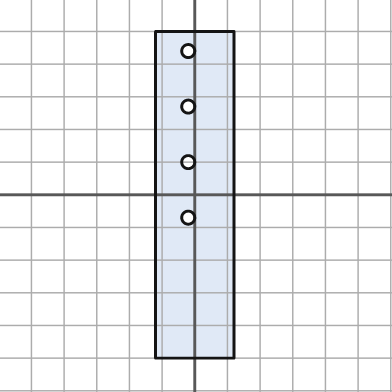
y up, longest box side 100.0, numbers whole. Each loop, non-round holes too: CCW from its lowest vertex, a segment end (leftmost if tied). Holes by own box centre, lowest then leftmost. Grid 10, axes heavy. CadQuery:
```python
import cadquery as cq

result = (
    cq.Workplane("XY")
    .moveTo(-12.0, -50.0)
    .lineTo(12.0, -50.0)
    .lineTo(12.0, 50.0)
    .lineTo(-12.0, 50.0)
    .close()
    .moveTo(-2.0, -7.0)
    .circle(2.0)
    .moveTo(-2.0, 10.0)
    .circle(2.0)
    .moveTo(-2.0, 27.0)
    .circle(2.0)
    .moveTo(-2.0, 44.0)
    .circle(2.0)
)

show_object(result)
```